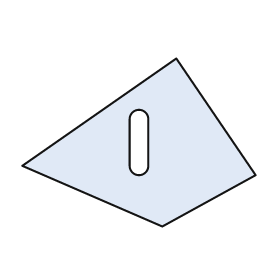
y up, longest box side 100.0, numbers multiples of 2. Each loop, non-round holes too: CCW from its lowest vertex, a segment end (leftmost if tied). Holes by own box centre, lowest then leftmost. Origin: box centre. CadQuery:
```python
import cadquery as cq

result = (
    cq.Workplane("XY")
    .moveTo(10.0, -36.0)
    .lineTo(50.0, -14.0)
    .lineTo(16.0, 36.0)
    .lineTo(-50.0, -10.0)
    .close()
    .moveTo(-4.0, -10.0)
    .threePointArc((0.0, -14.0), (4.0, -10.0))
    .lineTo(4.0, 10.0)
    .threePointArc((0.0, 14.0), (-4.0, 10.0))
    .close()
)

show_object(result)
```